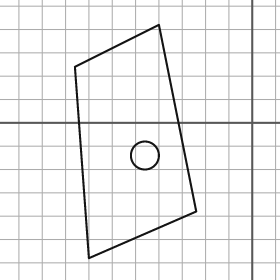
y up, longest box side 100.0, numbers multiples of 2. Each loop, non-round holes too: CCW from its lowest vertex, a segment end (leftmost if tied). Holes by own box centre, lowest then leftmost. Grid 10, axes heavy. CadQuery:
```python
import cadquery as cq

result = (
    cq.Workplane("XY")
    .moveTo(-70.0, -58.0)
    .lineTo(-24.0, -38.0)
    .lineTo(-40.0, 42.0)
    .lineTo(-76.0, 24.0)
    .close()
    .moveTo(-46.0, -14.0)
    .circle(6.0)
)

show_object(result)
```